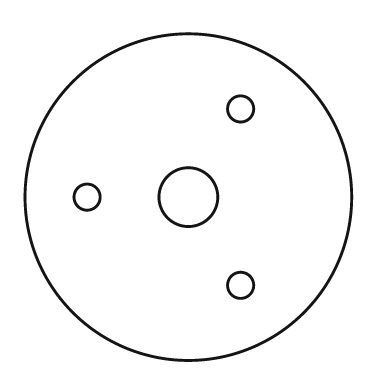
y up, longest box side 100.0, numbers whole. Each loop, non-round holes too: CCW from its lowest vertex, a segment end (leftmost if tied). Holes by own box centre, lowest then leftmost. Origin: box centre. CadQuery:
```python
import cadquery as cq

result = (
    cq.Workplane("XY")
    .moveTo(0.0, 0.0)
    .circle(50.0)
    .moveTo(16.0, -27.0)
    .circle(4.0)
    .moveTo(-31.0, 0.0)
    .circle(4.0)
    .moveTo(0.0, 0.0)
    .circle(9.0)
    .moveTo(16.0, 27.0)
    .circle(4.0)
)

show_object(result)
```